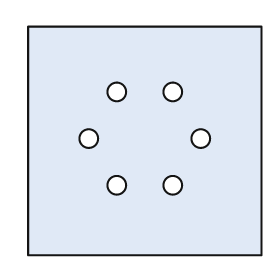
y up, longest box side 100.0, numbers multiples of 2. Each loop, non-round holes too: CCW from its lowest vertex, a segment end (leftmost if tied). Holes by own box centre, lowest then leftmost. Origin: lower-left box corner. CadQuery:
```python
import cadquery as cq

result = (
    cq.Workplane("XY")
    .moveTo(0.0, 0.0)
    .lineTo(100.0, 0.0)
    .lineTo(100.0, 98.0)
    .lineTo(0.0, 98.0)
    .close()
    .moveTo(38.0, 30.0)
    .circle(4.0)
    .moveTo(62.0, 30.0)
    .circle(4.0)
    .moveTo(26.0, 50.0)
    .circle(4.0)
    .moveTo(74.0, 50.0)
    .circle(4.0)
    .moveTo(38.0, 70.0)
    .circle(4.0)
    .moveTo(62.0, 70.0)
    .circle(4.0)
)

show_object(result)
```